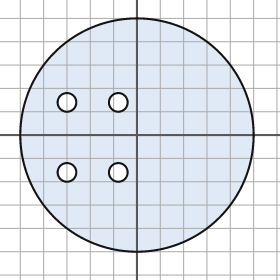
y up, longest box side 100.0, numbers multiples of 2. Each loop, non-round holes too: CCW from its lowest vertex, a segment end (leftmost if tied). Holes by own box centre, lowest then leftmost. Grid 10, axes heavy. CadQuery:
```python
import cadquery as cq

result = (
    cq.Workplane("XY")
    .moveTo(0.0, 0.0)
    .circle(50.0)
    .moveTo(-30.0, -16.0)
    .circle(4.0)
    .moveTo(-8.0, -16.0)
    .circle(4.0)
    .moveTo(-30.0, 14.0)
    .circle(4.0)
    .moveTo(-8.0, 14.0)
    .circle(4.0)
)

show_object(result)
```